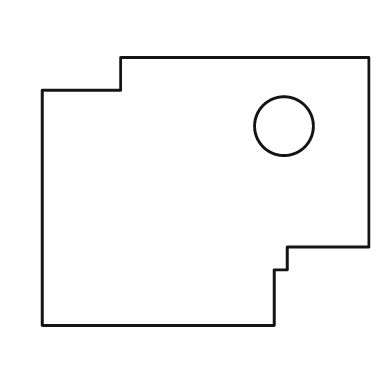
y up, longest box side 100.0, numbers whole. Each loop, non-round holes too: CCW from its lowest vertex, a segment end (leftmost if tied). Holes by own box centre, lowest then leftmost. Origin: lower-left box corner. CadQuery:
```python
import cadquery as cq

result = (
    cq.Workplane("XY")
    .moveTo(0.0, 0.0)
    .lineTo(71.0, 0.0)
    .lineTo(71.0, 17.0)
    .lineTo(75.0, 17.0)
    .lineTo(75.0, 24.0)
    .lineTo(100.0, 24.0)
    .lineTo(100.0, 82.0)
    .lineTo(24.0, 82.0)
    .lineTo(24.0, 72.0)
    .lineTo(0.0, 72.0)
    .close()
    .moveTo(74.0, 61.0)
    .circle(9.0)
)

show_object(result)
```